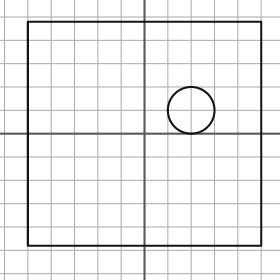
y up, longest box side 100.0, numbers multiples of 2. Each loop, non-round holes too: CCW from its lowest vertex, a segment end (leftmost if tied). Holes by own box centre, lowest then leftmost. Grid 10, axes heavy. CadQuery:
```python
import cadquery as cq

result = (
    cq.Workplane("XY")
    .moveTo(-50.0, -48.0)
    .lineTo(50.0, -48.0)
    .lineTo(50.0, 48.0)
    .lineTo(-50.0, 48.0)
    .close()
    .moveTo(20.0, 10.0)
    .circle(10.0)
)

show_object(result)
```